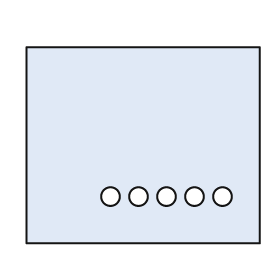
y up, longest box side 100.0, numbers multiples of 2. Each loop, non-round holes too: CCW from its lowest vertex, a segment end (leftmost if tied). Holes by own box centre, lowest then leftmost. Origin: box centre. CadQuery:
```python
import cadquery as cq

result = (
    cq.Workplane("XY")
    .moveTo(-50.0, -42.0)
    .lineTo(50.0, -42.0)
    .lineTo(50.0, 42.0)
    .lineTo(-50.0, 42.0)
    .close()
    .moveTo(-14.0, -22.0)
    .circle(4.0)
    .moveTo(-2.0, -22.0)
    .circle(4.0)
    .moveTo(10.0, -22.0)
    .circle(4.0)
    .moveTo(22.0, -22.0)
    .circle(4.0)
    .moveTo(34.0, -22.0)
    .circle(4.0)
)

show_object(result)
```